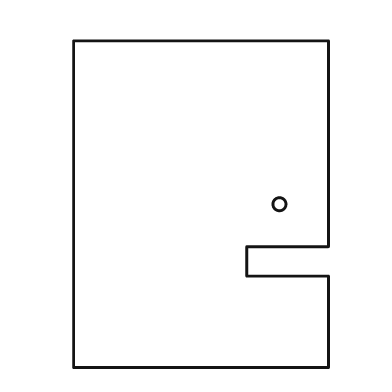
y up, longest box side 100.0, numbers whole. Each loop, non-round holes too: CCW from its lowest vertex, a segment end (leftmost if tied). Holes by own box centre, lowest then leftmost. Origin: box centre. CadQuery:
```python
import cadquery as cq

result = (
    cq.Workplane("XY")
    .moveTo(-39.0, -50.0)
    .lineTo(39.0, -50.0)
    .lineTo(39.0, -22.0)
    .lineTo(14.0, -22.0)
    .lineTo(14.0, -13.0)
    .lineTo(39.0, -13.0)
    .lineTo(39.0, 50.0)
    .lineTo(-39.0, 50.0)
    .close()
    .moveTo(24.0, 0.0)
    .circle(2.0)
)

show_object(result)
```